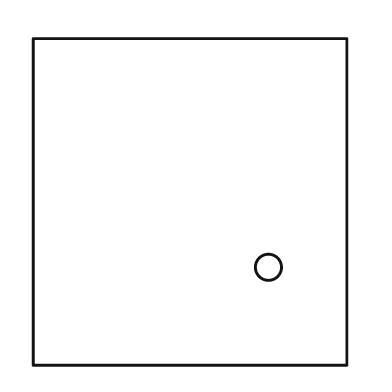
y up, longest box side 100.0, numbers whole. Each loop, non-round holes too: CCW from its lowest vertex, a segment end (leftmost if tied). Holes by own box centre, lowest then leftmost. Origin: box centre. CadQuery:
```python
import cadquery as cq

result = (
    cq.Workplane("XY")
    .moveTo(-48.0, -50.0)
    .lineTo(48.0, -50.0)
    .lineTo(48.0, 50.0)
    .lineTo(-48.0, 50.0)
    .close()
    .moveTo(24.0, -20.0)
    .circle(4.0)
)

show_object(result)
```